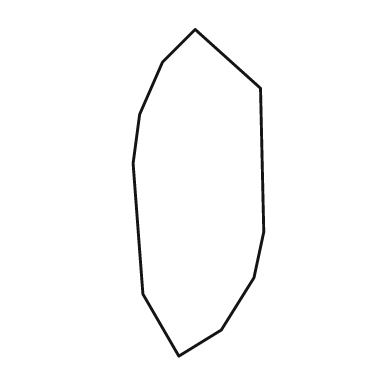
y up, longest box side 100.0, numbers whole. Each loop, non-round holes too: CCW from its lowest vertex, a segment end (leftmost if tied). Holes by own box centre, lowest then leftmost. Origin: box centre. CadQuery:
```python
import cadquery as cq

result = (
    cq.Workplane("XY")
    .moveTo(-6.0, -50.0)
    .lineTo(7.0, -42.0)
    .lineTo(17.0, -26.0)
    .lineTo(20.0, -12.0)
    .lineTo(19.0, 32.0)
    .lineTo(-1.0, 50.0)
    .lineTo(-11.0, 40.0)
    .lineTo(-18.0, 24.0)
    .lineTo(-20.0, 9.0)
    .lineTo(-17.0, -31.0)
    .close()
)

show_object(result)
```